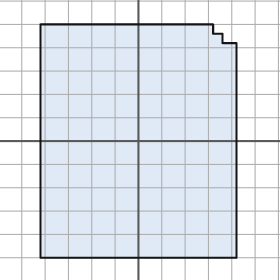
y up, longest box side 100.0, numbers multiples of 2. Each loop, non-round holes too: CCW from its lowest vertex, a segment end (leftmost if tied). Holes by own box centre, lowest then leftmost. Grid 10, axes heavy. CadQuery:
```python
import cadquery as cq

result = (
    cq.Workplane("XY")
    .moveTo(-42.0, -50.0)
    .lineTo(42.0, -50.0)
    .lineTo(42.0, 42.0)
    .lineTo(36.0, 42.0)
    .lineTo(36.0, 46.0)
    .lineTo(32.0, 46.0)
    .lineTo(32.0, 50.0)
    .lineTo(-42.0, 50.0)
    .close()
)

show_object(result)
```